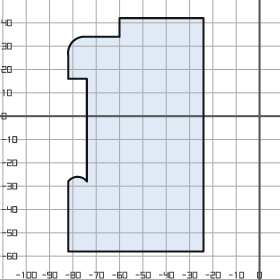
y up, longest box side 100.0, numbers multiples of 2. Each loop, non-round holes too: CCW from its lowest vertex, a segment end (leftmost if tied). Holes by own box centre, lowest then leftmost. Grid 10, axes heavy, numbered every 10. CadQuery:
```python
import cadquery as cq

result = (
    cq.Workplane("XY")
    .moveTo(-82.0, -58.0)
    .lineTo(-24.0, -58.0)
    .lineTo(-24.0, 42.0)
    .lineTo(-60.0, 42.0)
    .lineTo(-60.0, 34.0)
    .lineTo(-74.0, 34.0)
    .threePointArc((-80.0, 32.0), (-82.0, 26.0))
    .lineTo(-82.0, 16.0)
    .lineTo(-74.0, 16.0)
    .lineTo(-74.0, -28.0)
    .threePointArc((-78.0, -26.0), (-82.0, -28.0))
    .close()
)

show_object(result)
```